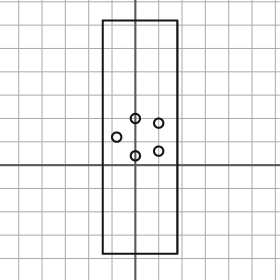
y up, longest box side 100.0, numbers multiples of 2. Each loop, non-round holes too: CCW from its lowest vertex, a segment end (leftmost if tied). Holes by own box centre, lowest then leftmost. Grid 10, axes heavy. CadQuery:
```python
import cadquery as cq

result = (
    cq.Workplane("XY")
    .moveTo(-14.0, -38.0)
    .lineTo(18.0, -38.0)
    .lineTo(18.0, 62.0)
    .lineTo(-14.0, 62.0)
    .close()
    .moveTo(0.0, 4.0)
    .circle(2.0)
    .moveTo(10.0, 6.0)
    .circle(2.0)
    .moveTo(-8.0, 12.0)
    .circle(2.0)
    .moveTo(10.0, 18.0)
    .circle(2.0)
    .moveTo(0.0, 20.0)
    .circle(2.0)
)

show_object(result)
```